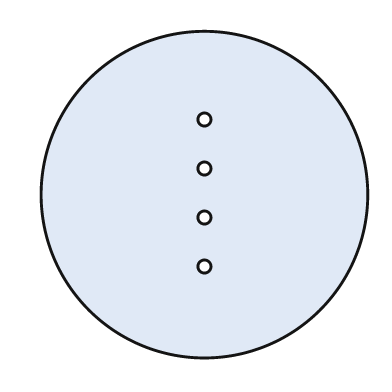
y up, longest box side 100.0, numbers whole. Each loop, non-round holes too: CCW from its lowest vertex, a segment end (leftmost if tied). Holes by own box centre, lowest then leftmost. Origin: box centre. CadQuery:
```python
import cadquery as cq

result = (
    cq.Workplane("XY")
    .moveTo(0.0, 0.0)
    .circle(50.0)
    .moveTo(0.0, -22.0)
    .circle(2.0)
    .moveTo(0.0, -7.0)
    .circle(2.0)
    .moveTo(0.0, 8.0)
    .circle(2.0)
    .moveTo(0.0, 23.0)
    .circle(2.0)
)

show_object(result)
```